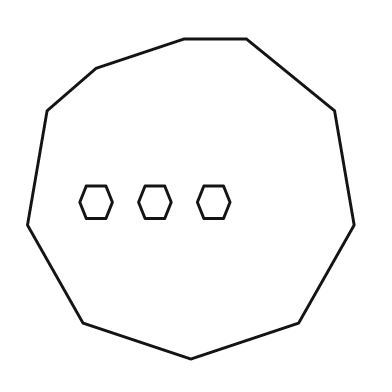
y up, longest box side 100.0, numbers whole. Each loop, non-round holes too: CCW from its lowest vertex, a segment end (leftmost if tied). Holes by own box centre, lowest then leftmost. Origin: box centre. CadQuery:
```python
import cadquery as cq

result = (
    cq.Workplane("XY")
    .moveTo(0.0, -49.0)
    .lineTo(33.0, -38.0)
    .lineTo(50.0, -8.0)
    .lineTo(44.0, 27.0)
    .lineTo(17.0, 49.0)
    .lineTo(-2.0, 49.0)
    .lineTo(-29.0, 40.0)
    .lineTo(-44.0, 27.0)
    .lineTo(-50.0, -8.0)
    .lineTo(-33.0, -38.0)
    .close()
    .moveTo(-32.0, -6.0)
    .lineTo(-26.0, -6.0)
    .lineTo(-24.0, -1.0)
    .lineTo(-26.0, 4.0)
    .lineTo(-32.0, 4.0)
    .lineTo(-34.0, -1.0)
    .close()
    .moveTo(-14.0, -6.0)
    .lineTo(-8.0, -6.0)
    .lineTo(-6.0, -1.0)
    .lineTo(-8.0, 4.0)
    .lineTo(-14.0, 4.0)
    .lineTo(-16.0, -1.0)
    .close()
    .moveTo(4.0, -6.0)
    .lineTo(10.0, -6.0)
    .lineTo(12.0, -1.0)
    .lineTo(10.0, 4.0)
    .lineTo(4.0, 4.0)
    .lineTo(2.0, -1.0)
    .close()
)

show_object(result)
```